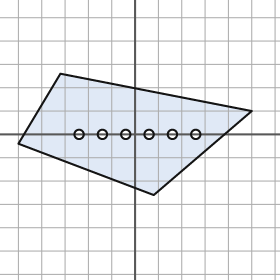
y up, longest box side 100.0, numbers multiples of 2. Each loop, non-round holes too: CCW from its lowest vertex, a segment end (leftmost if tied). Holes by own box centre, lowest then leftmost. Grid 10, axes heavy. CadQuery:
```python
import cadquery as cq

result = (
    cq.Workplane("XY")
    .moveTo(8.0, -26.0)
    .lineTo(50.0, 10.0)
    .lineTo(-32.0, 26.0)
    .lineTo(-50.0, -4.0)
    .close()
    .moveTo(-24.0, 0.0)
    .circle(2.0)
    .moveTo(-14.0, 0.0)
    .circle(2.0)
    .moveTo(-4.0, 0.0)
    .circle(2.0)
    .moveTo(6.0, 0.0)
    .circle(2.0)
    .moveTo(16.0, 0.0)
    .circle(2.0)
    .moveTo(26.0, 0.0)
    .circle(2.0)
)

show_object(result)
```